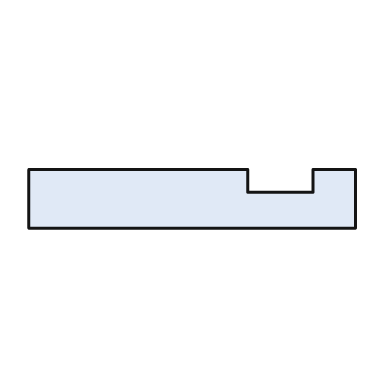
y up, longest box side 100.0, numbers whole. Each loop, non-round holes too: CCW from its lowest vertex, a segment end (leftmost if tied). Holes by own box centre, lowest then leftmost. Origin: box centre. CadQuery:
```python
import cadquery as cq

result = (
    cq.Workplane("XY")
    .moveTo(-50.0, -9.0)
    .lineTo(50.0, -9.0)
    .lineTo(50.0, 9.0)
    .lineTo(37.0, 9.0)
    .lineTo(37.0, 2.0)
    .lineTo(17.0, 2.0)
    .lineTo(17.0, 9.0)
    .lineTo(-50.0, 9.0)
    .close()
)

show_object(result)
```